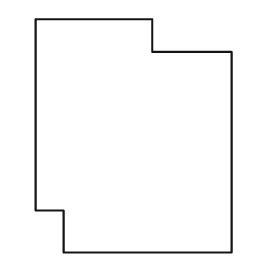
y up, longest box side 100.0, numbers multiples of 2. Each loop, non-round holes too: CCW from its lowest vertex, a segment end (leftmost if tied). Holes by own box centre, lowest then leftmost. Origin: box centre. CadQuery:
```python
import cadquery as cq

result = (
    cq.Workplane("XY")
    .moveTo(-30.0, -50.0)
    .lineTo(42.0, -50.0)
    .lineTo(42.0, 36.0)
    .lineTo(8.0, 36.0)
    .lineTo(8.0, 50.0)
    .lineTo(-42.0, 50.0)
    .lineTo(-42.0, -32.0)
    .lineTo(-30.0, -32.0)
    .close()
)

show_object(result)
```